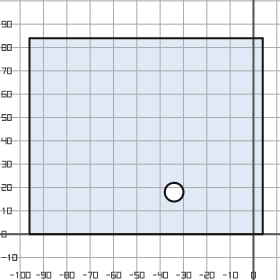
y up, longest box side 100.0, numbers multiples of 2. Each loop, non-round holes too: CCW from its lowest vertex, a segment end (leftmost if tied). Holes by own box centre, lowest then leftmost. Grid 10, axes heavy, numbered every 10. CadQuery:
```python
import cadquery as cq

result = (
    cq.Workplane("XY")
    .moveTo(-96.0, 0.0)
    .lineTo(4.0, 0.0)
    .lineTo(4.0, 84.0)
    .lineTo(-96.0, 84.0)
    .close()
    .moveTo(-34.0, 18.0)
    .circle(4.0)
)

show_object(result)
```